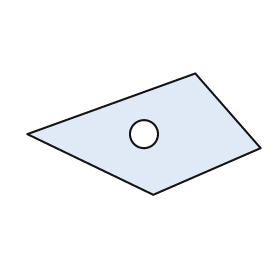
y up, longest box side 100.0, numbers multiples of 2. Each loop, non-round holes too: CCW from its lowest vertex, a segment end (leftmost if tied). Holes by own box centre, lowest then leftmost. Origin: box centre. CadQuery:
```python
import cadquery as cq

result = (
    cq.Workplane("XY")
    .moveTo(4.0, -26.0)
    .lineTo(50.0, -6.0)
    .lineTo(22.0, 26.0)
    .lineTo(-50.0, 0.0)
    .close()
    .moveTo(0.0, 0.0)
    .circle(6.0)
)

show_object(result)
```